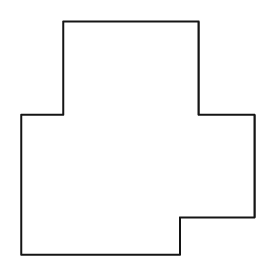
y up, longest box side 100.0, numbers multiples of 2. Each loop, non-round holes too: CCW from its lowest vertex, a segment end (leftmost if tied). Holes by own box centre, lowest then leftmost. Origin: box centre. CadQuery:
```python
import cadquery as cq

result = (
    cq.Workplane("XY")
    .moveTo(-50.0, -50.0)
    .lineTo(18.0, -50.0)
    .lineTo(18.0, -34.0)
    .lineTo(50.0, -34.0)
    .lineTo(50.0, 10.0)
    .lineTo(26.0, 10.0)
    .lineTo(26.0, 50.0)
    .lineTo(-32.0, 50.0)
    .lineTo(-32.0, 10.0)
    .lineTo(-50.0, 10.0)
    .close()
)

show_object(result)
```